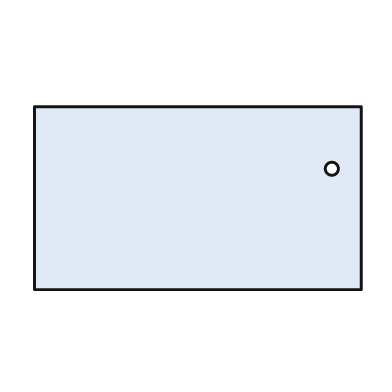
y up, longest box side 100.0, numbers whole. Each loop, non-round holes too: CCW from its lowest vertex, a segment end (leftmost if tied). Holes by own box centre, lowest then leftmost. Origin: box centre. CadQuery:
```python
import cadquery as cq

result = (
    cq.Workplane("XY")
    .moveTo(-50.0, -28.0)
    .lineTo(50.0, -28.0)
    .lineTo(50.0, 28.0)
    .lineTo(-50.0, 28.0)
    .close()
    .moveTo(41.0, 9.0)
    .circle(2.0)
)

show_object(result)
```